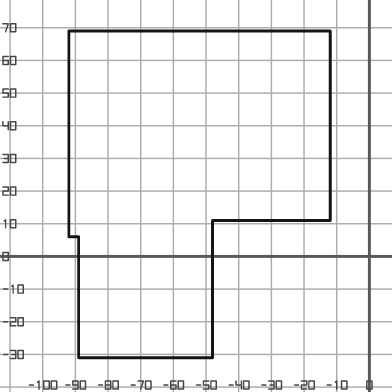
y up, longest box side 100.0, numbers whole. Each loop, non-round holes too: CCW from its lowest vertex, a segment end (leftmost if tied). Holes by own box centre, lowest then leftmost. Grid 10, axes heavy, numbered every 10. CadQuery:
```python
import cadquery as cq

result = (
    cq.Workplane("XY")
    .moveTo(-89.0, -31.0)
    .lineTo(-48.0, -31.0)
    .lineTo(-48.0, 11.0)
    .lineTo(-12.0, 11.0)
    .lineTo(-12.0, 69.0)
    .lineTo(-92.0, 69.0)
    .lineTo(-92.0, 6.0)
    .lineTo(-89.0, 6.0)
    .close()
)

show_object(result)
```